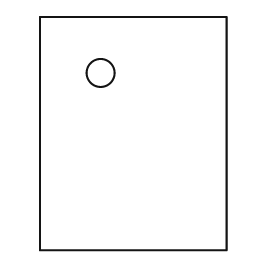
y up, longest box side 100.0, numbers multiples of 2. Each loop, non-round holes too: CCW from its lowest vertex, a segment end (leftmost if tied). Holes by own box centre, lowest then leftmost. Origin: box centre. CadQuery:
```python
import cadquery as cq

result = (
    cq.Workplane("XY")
    .moveTo(-40.0, -50.0)
    .lineTo(40.0, -50.0)
    .lineTo(40.0, 50.0)
    .lineTo(-40.0, 50.0)
    .close()
    .moveTo(-14.0, 26.0)
    .circle(6.0)
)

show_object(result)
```